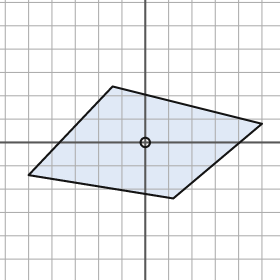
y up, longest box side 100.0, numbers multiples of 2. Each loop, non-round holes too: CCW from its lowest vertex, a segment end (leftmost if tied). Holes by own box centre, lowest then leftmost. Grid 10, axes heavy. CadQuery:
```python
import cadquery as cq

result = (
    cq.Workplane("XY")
    .moveTo(12.0, -24.0)
    .lineTo(50.0, 8.0)
    .lineTo(-14.0, 24.0)
    .lineTo(-50.0, -14.0)
    .close()
    .moveTo(0.0, 0.0)
    .circle(2.0)
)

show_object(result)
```